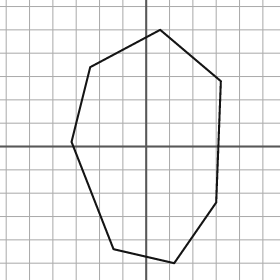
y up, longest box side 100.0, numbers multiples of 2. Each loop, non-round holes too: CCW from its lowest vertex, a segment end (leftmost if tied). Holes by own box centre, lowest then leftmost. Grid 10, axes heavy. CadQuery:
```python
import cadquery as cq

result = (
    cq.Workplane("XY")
    .moveTo(12.0, -50.0)
    .lineTo(30.0, -24.0)
    .lineTo(32.0, 28.0)
    .lineTo(6.0, 50.0)
    .lineTo(-24.0, 34.0)
    .lineTo(-32.0, 2.0)
    .lineTo(-14.0, -44.0)
    .close()
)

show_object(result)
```